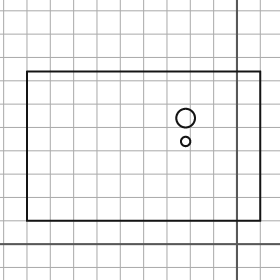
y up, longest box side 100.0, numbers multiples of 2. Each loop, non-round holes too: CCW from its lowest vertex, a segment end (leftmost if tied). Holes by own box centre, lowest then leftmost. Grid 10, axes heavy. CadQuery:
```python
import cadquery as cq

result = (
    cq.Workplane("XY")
    .moveTo(-90.0, 10.0)
    .lineTo(10.0, 10.0)
    .lineTo(10.0, 74.0)
    .lineTo(-90.0, 74.0)
    .close()
    .moveTo(-22.0, 44.0)
    .circle(2.0)
    .moveTo(-22.0, 54.0)
    .circle(4.0)
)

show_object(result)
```